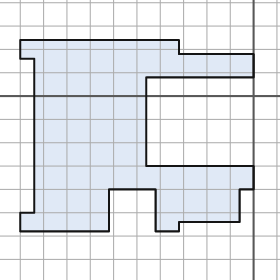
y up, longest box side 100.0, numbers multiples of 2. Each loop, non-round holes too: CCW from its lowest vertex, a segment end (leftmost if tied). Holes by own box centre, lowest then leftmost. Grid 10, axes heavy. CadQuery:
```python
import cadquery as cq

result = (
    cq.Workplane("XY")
    .moveTo(-100.0, -58.0)
    .lineTo(-62.0, -58.0)
    .lineTo(-62.0, -40.0)
    .lineTo(-42.0, -40.0)
    .lineTo(-42.0, -58.0)
    .lineTo(-32.0, -58.0)
    .lineTo(-32.0, -54.0)
    .lineTo(-6.0, -54.0)
    .lineTo(-6.0, -40.0)
    .lineTo(0.0, -40.0)
    .lineTo(0.0, -30.0)
    .lineTo(-46.0, -30.0)
    .lineTo(-46.0, 8.0)
    .lineTo(0.0, 8.0)
    .lineTo(0.0, 18.0)
    .lineTo(-32.0, 18.0)
    .lineTo(-32.0, 24.0)
    .lineTo(-100.0, 24.0)
    .lineTo(-100.0, 16.0)
    .lineTo(-94.0, 16.0)
    .lineTo(-94.0, -50.0)
    .lineTo(-100.0, -50.0)
    .close()
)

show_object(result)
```